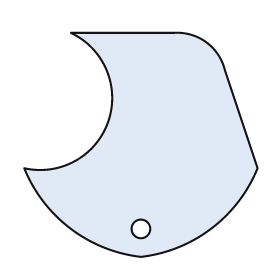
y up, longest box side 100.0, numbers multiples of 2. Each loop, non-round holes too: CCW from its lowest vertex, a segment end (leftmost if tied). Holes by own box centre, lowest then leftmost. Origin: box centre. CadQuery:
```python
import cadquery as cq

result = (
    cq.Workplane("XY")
    .moveTo(0.0, -48.0)
    .threePointArc((30.0, -36.0), (50.0, -10.0))
    .lineTo(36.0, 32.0)
    .threePointArc((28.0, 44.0), (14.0, 48.0))
    .lineTo(-30.0, 48.0)
    .threePointArc((-14.0, 10.0), (-50.0, -10.0))
    .threePointArc((-30.0, -36.0), (0.0, -48.0))
    .close()
    .moveTo(0.0, -36.0)
    .circle(4.0)
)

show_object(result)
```